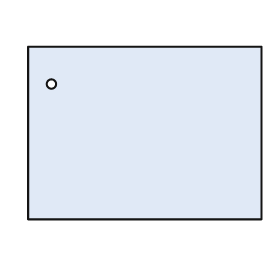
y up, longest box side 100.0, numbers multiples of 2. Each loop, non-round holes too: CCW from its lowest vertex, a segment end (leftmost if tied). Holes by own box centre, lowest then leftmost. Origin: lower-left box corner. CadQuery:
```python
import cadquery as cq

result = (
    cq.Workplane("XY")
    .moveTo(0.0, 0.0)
    .lineTo(100.0, 0.0)
    .lineTo(100.0, 74.0)
    .lineTo(0.0, 74.0)
    .close()
    .moveTo(10.0, 58.0)
    .circle(2.0)
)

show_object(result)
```